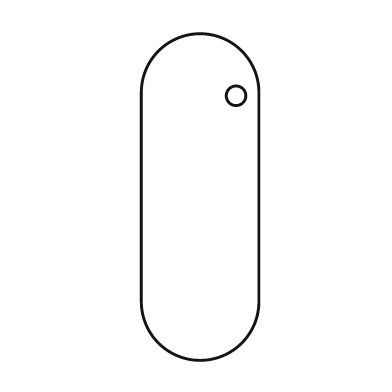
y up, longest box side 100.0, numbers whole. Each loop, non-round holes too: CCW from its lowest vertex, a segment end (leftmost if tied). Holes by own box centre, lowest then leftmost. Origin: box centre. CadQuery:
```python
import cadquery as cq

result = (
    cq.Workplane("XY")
    .moveTo(-18.0, -32.0)
    .threePointArc((0.0, -50.0), (18.0, -32.0))
    .lineTo(18.0, 32.0)
    .threePointArc((0.0, 50.0), (-18.0, 32.0))
    .close()
    .moveTo(11.0, 31.0)
    .circle(3.0)
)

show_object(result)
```